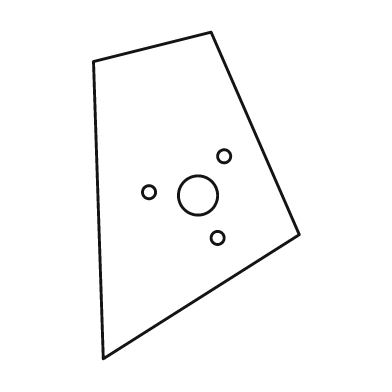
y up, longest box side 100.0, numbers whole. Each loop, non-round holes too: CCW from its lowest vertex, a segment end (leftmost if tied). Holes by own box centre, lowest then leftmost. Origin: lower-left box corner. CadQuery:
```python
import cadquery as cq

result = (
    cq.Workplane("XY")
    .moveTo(3.0, 0.0)
    .lineTo(63.0, 38.0)
    .lineTo(36.0, 100.0)
    .lineTo(0.0, 91.0)
    .close()
    .moveTo(38.0, 37.0)
    .circle(2.0)
    .moveTo(32.0, 50.0)
    .circle(6.0)
    .moveTo(17.0, 51.0)
    .circle(2.0)
    .moveTo(40.0, 62.0)
    .circle(2.0)
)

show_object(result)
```